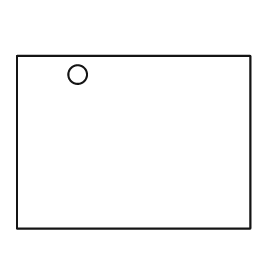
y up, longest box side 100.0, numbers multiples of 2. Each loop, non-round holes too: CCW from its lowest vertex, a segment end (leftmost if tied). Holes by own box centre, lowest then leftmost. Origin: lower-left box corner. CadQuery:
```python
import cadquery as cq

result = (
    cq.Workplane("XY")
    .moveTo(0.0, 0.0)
    .lineTo(100.0, 0.0)
    .lineTo(100.0, 74.0)
    .lineTo(0.0, 74.0)
    .close()
    .moveTo(26.0, 66.0)
    .circle(4.0)
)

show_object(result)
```